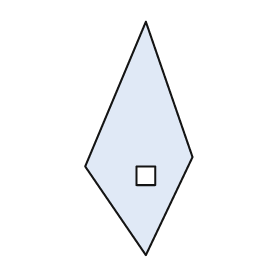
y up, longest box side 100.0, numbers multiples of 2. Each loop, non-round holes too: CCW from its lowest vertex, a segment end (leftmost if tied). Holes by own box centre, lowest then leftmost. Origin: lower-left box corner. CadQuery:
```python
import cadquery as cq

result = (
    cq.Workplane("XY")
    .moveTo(26.0, 0.0)
    .lineTo(46.0, 42.0)
    .lineTo(26.0, 100.0)
    .lineTo(0.0, 38.0)
    .close()
    .moveTo(22.0, 30.0)
    .lineTo(30.0, 30.0)
    .lineTo(30.0, 38.0)
    .lineTo(22.0, 38.0)
    .close()
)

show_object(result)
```